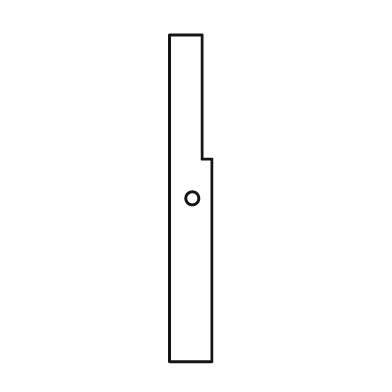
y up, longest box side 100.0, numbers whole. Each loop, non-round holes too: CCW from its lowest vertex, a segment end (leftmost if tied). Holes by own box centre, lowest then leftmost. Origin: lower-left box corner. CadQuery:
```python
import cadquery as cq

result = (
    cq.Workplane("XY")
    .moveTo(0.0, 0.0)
    .lineTo(13.0, 0.0)
    .lineTo(13.0, 62.0)
    .lineTo(10.0, 62.0)
    .lineTo(10.0, 100.0)
    .lineTo(0.0, 100.0)
    .close()
    .moveTo(7.0, 50.0)
    .circle(2.0)
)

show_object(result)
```